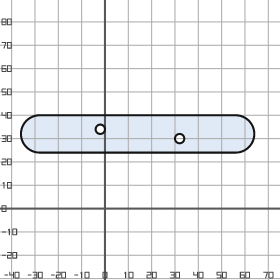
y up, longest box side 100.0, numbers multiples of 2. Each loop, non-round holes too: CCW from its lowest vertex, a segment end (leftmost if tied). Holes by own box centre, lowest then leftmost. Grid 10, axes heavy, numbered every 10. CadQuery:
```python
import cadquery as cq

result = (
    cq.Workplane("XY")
    .moveTo(-28.0, 24.0)
    .lineTo(56.0, 24.0)
    .threePointArc((64.0, 32.0), (56.0, 40.0))
    .lineTo(-28.0, 40.0)
    .threePointArc((-36.0, 32.0), (-28.0, 24.0))
    .close()
    .moveTo(32.0, 30.0)
    .circle(2.0)
    .moveTo(-2.0, 34.0)
    .circle(2.0)
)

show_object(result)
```